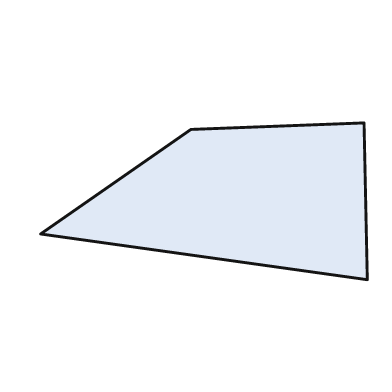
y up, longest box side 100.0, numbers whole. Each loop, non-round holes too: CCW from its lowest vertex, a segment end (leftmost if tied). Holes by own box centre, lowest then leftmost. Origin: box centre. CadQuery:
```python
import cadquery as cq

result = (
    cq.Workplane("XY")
    .moveTo(50.0, -24.0)
    .lineTo(49.0, 24.0)
    .lineTo(-4.0, 22.0)
    .lineTo(-50.0, -10.0)
    .close()
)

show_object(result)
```